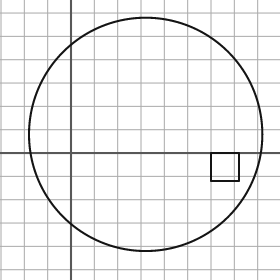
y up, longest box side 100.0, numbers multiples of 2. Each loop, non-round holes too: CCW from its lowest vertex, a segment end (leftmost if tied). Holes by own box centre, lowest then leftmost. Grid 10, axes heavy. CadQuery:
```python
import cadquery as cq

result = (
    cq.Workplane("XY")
    .moveTo(32.0, 8.0)
    .circle(50.0)
    .moveTo(60.0, -12.0)
    .lineTo(72.0, -12.0)
    .lineTo(72.0, 0.0)
    .lineTo(60.0, 0.0)
    .close()
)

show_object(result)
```